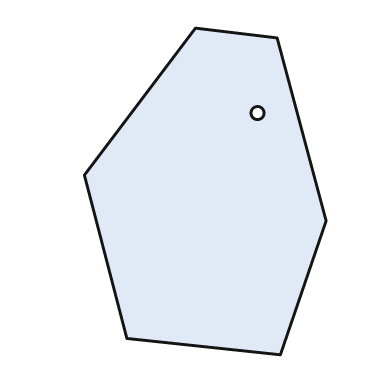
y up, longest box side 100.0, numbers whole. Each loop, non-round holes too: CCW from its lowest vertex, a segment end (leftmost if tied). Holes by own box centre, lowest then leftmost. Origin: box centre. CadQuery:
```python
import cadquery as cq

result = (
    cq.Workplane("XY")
    .moveTo(23.0, -50.0)
    .lineTo(37.0, -9.0)
    .lineTo(22.0, 47.0)
    .lineTo(-3.0, 50.0)
    .lineTo(-37.0, 5.0)
    .lineTo(-24.0, -45.0)
    .close()
    .moveTo(16.0, 24.0)
    .circle(2.0)
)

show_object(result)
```